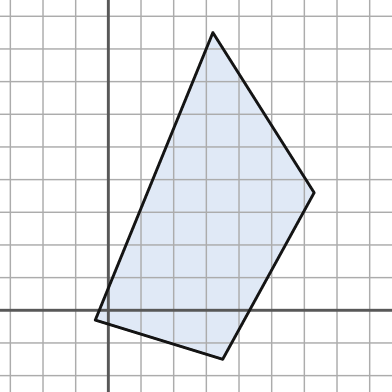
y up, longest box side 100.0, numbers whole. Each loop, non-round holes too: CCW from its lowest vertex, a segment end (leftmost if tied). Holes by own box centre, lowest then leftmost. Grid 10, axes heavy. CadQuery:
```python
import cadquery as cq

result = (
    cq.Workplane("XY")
    .moveTo(35.0, -15.0)
    .lineTo(63.0, 36.0)
    .lineTo(32.0, 85.0)
    .lineTo(-4.0, -3.0)
    .close()
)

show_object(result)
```